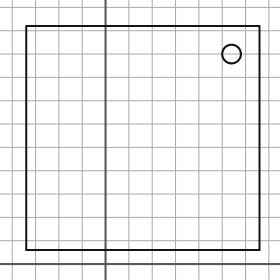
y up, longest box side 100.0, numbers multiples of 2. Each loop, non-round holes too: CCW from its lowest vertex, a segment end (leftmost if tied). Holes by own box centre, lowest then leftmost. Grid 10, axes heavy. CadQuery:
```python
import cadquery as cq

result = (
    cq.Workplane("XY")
    .moveTo(-34.0, 6.0)
    .lineTo(66.0, 6.0)
    .lineTo(66.0, 102.0)
    .lineTo(-34.0, 102.0)
    .close()
    .moveTo(54.0, 90.0)
    .circle(4.0)
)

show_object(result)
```